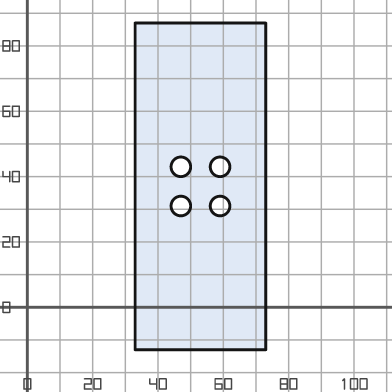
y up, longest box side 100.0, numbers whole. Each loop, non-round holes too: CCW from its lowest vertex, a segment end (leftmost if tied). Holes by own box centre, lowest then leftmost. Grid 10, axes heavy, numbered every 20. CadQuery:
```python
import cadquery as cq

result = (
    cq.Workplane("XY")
    .moveTo(33.0, -13.0)
    .lineTo(73.0, -13.0)
    .lineTo(73.0, 87.0)
    .lineTo(33.0, 87.0)
    .close()
    .moveTo(47.0, 31.0)
    .circle(3.0)
    .moveTo(59.0, 31.0)
    .circle(3.0)
    .moveTo(47.0, 43.0)
    .circle(3.0)
    .moveTo(59.0, 43.0)
    .circle(3.0)
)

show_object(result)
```